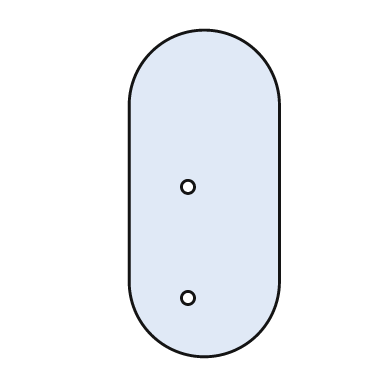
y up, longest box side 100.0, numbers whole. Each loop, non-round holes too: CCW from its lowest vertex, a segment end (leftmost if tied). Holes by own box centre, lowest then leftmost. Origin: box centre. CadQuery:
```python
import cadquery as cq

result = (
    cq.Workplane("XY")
    .moveTo(-23.0, -27.0)
    .threePointArc((0.0, -50.0), (23.0, -27.0))
    .lineTo(23.0, 27.0)
    .threePointArc((0.0, 50.0), (-23.0, 27.0))
    .close()
    .moveTo(-5.0, -32.0)
    .circle(2.0)
    .moveTo(-5.0, 2.0)
    .circle(2.0)
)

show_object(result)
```